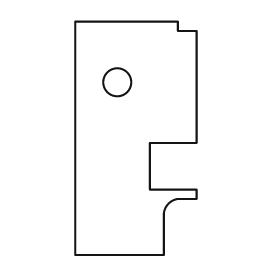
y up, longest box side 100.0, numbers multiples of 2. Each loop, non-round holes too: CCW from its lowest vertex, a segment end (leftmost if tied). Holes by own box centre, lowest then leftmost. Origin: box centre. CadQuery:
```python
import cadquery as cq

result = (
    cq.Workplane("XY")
    .moveTo(-26.0, -50.0)
    .lineTo(12.0, -50.0)
    .lineTo(12.0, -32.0)
    .threePointArc((14.0, -28.0), (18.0, -26.0))
    .lineTo(26.0, -26.0)
    .lineTo(26.0, -22.0)
    .lineTo(6.0, -22.0)
    .lineTo(6.0, -2.0)
    .lineTo(26.0, -2.0)
    .lineTo(26.0, 46.0)
    .lineTo(18.0, 46.0)
    .lineTo(18.0, 50.0)
    .lineTo(-26.0, 50.0)
    .close()
    .moveTo(-8.0, 24.0)
    .circle(6.0)
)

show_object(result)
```